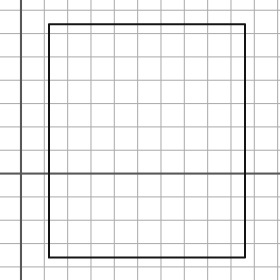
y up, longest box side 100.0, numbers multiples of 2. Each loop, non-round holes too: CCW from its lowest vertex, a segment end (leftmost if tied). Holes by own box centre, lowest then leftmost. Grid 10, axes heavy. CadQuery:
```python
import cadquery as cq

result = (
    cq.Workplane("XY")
    .moveTo(12.0, -36.0)
    .lineTo(96.0, -36.0)
    .lineTo(96.0, 64.0)
    .lineTo(12.0, 64.0)
    .close()
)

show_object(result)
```